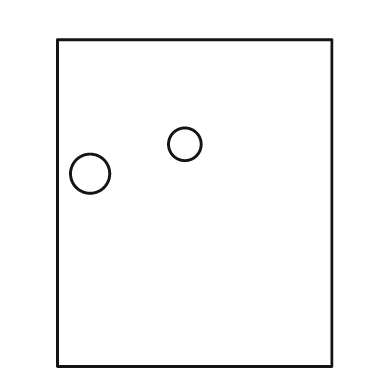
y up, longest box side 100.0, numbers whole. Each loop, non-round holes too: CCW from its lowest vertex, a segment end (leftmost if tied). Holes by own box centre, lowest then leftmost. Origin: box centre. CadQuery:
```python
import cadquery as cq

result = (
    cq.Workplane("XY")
    .moveTo(-42.0, -50.0)
    .lineTo(42.0, -50.0)
    .lineTo(42.0, 50.0)
    .lineTo(-42.0, 50.0)
    .close()
    .moveTo(-32.0, 9.0)
    .circle(6.0)
    .moveTo(-3.0, 18.0)
    .circle(5.0)
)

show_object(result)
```